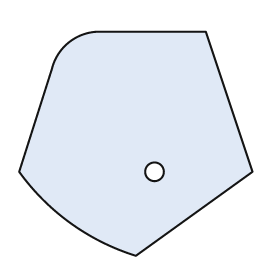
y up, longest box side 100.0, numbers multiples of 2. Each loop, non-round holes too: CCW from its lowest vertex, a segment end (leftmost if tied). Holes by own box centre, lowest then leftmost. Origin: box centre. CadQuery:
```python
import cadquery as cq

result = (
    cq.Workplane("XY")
    .moveTo(0.0, -48.0)
    .lineTo(50.0, -12.0)
    .lineTo(30.0, 48.0)
    .lineTo(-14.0, 48.0)
    .threePointArc((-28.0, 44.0), (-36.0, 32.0))
    .lineTo(-50.0, -12.0)
    .threePointArc((-28.0, -34.0), (0.0, -48.0))
    .close()
    .moveTo(8.0, -12.0)
    .circle(4.0)
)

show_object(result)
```